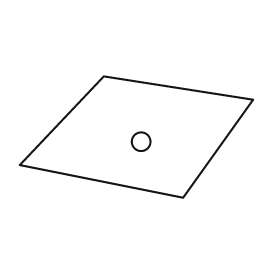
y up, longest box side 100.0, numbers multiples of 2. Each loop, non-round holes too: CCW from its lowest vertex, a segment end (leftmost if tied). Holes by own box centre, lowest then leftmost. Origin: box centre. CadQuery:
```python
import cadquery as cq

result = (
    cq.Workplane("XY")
    .moveTo(20.0, -26.0)
    .lineTo(50.0, 16.0)
    .lineTo(-14.0, 26.0)
    .lineTo(-50.0, -12.0)
    .close()
    .moveTo(2.0, -2.0)
    .circle(4.0)
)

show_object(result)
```